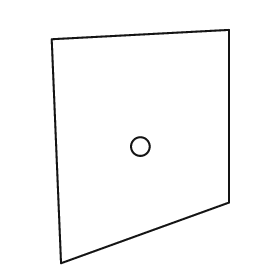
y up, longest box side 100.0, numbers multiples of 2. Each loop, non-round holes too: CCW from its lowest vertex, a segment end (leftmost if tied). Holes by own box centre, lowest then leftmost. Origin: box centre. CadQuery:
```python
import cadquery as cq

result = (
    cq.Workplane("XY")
    .moveTo(-34.0, -50.0)
    .lineTo(38.0, -24.0)
    .lineTo(38.0, 50.0)
    .lineTo(-38.0, 46.0)
    .close()
    .moveTo(0.0, 0.0)
    .circle(4.0)
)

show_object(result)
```